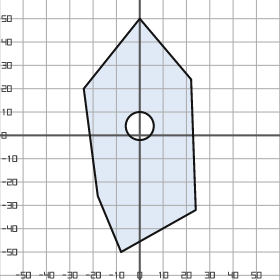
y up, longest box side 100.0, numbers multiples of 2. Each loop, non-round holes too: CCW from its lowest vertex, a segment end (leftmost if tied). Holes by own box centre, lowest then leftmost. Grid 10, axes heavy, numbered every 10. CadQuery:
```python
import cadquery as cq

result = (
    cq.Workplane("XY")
    .moveTo(-8.0, -50.0)
    .lineTo(24.0, -32.0)
    .lineTo(22.0, 24.0)
    .lineTo(0.0, 50.0)
    .lineTo(-24.0, 20.0)
    .lineTo(-18.0, -26.0)
    .close()
    .moveTo(0.0, 4.0)
    .circle(6.0)
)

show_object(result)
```